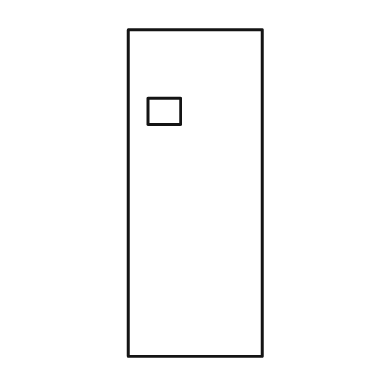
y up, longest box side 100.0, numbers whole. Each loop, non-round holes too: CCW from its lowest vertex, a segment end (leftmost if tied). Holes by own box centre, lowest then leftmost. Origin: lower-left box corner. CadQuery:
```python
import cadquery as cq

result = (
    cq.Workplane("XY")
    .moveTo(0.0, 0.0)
    .lineTo(41.0, 0.0)
    .lineTo(41.0, 100.0)
    .lineTo(0.0, 100.0)
    .close()
    .moveTo(6.0, 71.0)
    .lineTo(16.0, 71.0)
    .lineTo(16.0, 79.0)
    .lineTo(6.0, 79.0)
    .close()
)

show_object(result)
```